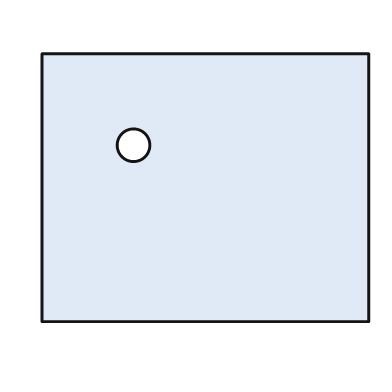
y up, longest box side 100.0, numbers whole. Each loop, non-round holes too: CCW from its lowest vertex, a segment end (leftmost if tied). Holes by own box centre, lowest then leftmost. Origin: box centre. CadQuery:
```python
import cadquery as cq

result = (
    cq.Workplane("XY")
    .moveTo(-50.0, -41.0)
    .lineTo(50.0, -41.0)
    .lineTo(50.0, 41.0)
    .lineTo(-50.0, 41.0)
    .close()
    .moveTo(-22.0, 13.0)
    .circle(5.0)
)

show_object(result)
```